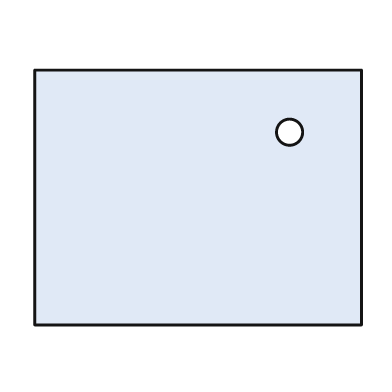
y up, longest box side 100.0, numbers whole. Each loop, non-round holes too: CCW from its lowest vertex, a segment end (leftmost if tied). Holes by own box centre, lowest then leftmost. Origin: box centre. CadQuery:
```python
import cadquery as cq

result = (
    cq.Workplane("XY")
    .moveTo(-50.0, -39.0)
    .lineTo(50.0, -39.0)
    .lineTo(50.0, 39.0)
    .lineTo(-50.0, 39.0)
    .close()
    .moveTo(28.0, 20.0)
    .circle(4.0)
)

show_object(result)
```